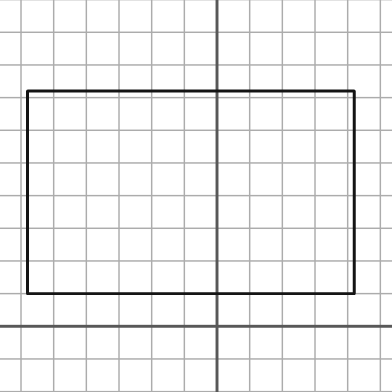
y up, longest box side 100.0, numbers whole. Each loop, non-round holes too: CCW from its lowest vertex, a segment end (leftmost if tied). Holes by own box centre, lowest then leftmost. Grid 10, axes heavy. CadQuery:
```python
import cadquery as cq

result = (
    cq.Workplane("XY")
    .moveTo(-58.0, 10.0)
    .lineTo(42.0, 10.0)
    .lineTo(42.0, 72.0)
    .lineTo(-58.0, 72.0)
    .close()
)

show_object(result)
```